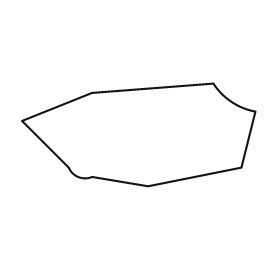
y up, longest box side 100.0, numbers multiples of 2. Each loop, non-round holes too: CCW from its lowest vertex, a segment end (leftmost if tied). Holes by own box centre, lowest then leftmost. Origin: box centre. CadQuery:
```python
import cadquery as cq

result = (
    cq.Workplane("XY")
    .moveTo(4.0, -22.0)
    .lineTo(44.0, -14.0)
    .lineTo(50.0, 10.0)
    .threePointArc((40.0, 14.0), (32.0, 22.0))
    .lineTo(-20.0, 18.0)
    .lineTo(-50.0, 6.0)
    .lineTo(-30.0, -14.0)
    .threePointArc((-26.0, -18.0), (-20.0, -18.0))
    .close()
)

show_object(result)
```